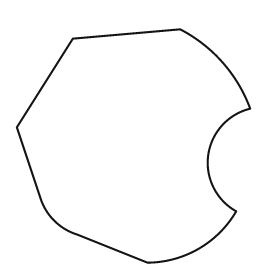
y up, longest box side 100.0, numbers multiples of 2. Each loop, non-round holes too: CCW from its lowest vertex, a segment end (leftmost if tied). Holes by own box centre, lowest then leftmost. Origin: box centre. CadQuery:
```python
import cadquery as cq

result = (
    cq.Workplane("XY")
    .moveTo(6.0, -50.0)
    .threePointArc((28.0, -44.0), (44.0, -28.0))
    .threePointArc((32.0, -4.0), (50.0, 16.0))
    .threePointArc((38.0, 36.0), (20.0, 50.0))
    .lineTo(-26.0, 46.0)
    .lineTo(-50.0, 8.0)
    .lineTo(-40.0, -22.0)
    .threePointArc((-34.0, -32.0), (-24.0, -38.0))
    .close()
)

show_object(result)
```